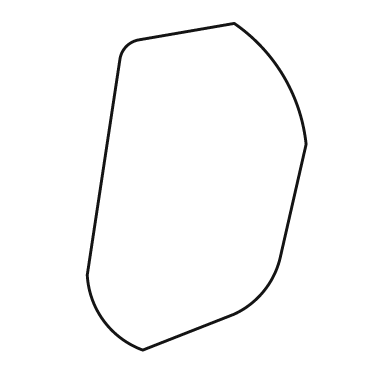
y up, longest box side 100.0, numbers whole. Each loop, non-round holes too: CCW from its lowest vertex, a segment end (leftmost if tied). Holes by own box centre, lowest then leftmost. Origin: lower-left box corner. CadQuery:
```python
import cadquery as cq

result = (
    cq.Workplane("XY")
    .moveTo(17.0, 0.0)
    .lineTo(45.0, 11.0)
    .threePointArc((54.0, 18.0), (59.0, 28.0))
    .lineTo(67.0, 63.0)
    .threePointArc((60.0, 84.0), (45.0, 100.0))
    .lineTo(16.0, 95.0)
    .threePointArc((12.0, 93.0), (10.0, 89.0))
    .lineTo(0.0, 23.0)
    .threePointArc((5.0, 9.0), (17.0, 0.0))
    .close()
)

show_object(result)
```